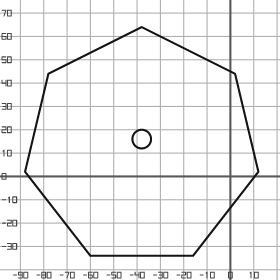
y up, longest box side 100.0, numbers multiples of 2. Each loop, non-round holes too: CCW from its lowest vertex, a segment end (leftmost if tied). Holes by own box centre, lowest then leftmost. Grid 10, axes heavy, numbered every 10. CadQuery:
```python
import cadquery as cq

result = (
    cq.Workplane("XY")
    .moveTo(-60.0, -34.0)
    .lineTo(-16.0, -34.0)
    .lineTo(12.0, 2.0)
    .lineTo(2.0, 44.0)
    .lineTo(-38.0, 64.0)
    .lineTo(-78.0, 44.0)
    .lineTo(-88.0, 2.0)
    .close()
    .moveTo(-38.0, 16.0)
    .circle(4.0)
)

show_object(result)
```